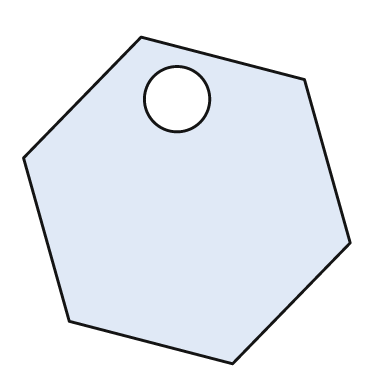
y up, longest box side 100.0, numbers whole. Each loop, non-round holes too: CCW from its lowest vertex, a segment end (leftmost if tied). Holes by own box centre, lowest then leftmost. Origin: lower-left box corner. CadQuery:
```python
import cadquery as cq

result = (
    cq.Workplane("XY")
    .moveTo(64.0, 0.0)
    .lineTo(100.0, 37.0)
    .lineTo(86.0, 87.0)
    .lineTo(36.0, 100.0)
    .lineTo(0.0, 63.0)
    .lineTo(14.0, 13.0)
    .close()
    .moveTo(47.0, 81.0)
    .circle(10.0)
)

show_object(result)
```